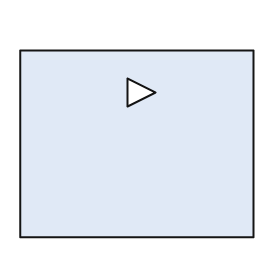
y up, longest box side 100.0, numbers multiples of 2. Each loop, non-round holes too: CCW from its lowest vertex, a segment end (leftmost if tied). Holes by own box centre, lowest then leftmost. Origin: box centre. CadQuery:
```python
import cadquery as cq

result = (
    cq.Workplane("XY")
    .moveTo(-50.0, -40.0)
    .lineTo(50.0, -40.0)
    .lineTo(50.0, 40.0)
    .lineTo(-50.0, 40.0)
    .close()
    .moveTo(-4.0, 16.0)
    .lineTo(8.0, 22.0)
    .lineTo(-4.0, 28.0)
    .close()
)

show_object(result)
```